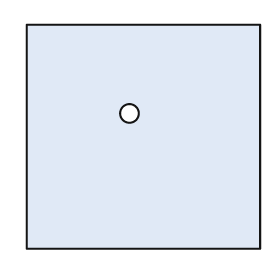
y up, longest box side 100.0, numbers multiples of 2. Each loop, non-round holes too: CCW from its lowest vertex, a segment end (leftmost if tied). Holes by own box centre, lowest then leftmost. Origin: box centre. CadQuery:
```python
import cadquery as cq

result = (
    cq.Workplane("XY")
    .moveTo(-50.0, -48.0)
    .lineTo(50.0, -48.0)
    .lineTo(50.0, 48.0)
    .lineTo(-50.0, 48.0)
    .close()
    .moveTo(-6.0, 10.0)
    .circle(4.0)
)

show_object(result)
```